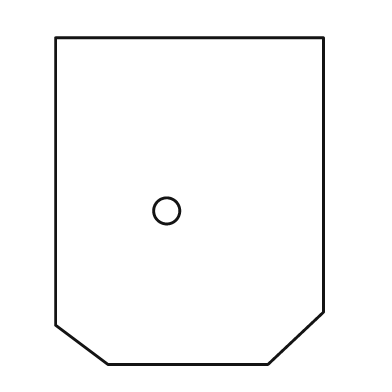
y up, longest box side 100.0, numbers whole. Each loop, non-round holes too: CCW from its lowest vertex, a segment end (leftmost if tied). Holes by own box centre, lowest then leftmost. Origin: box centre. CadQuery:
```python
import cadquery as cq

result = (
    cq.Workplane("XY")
    .moveTo(-25.0, -50.0)
    .lineTo(24.0, -50.0)
    .lineTo(41.0, -34.0)
    .lineTo(41.0, 50.0)
    .lineTo(-41.0, 50.0)
    .lineTo(-41.0, -38.0)
    .close()
    .moveTo(-7.0, -3.0)
    .circle(4.0)
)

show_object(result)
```